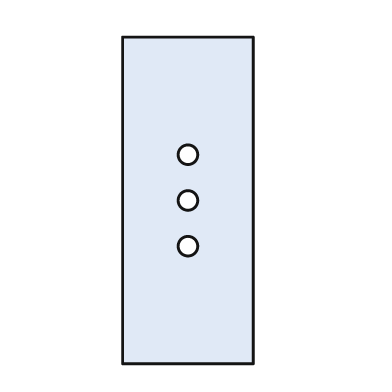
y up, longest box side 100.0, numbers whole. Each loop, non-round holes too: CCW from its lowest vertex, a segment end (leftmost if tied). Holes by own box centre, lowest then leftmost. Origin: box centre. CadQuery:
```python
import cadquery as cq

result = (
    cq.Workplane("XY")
    .moveTo(-20.0, -50.0)
    .lineTo(20.0, -50.0)
    .lineTo(20.0, 50.0)
    .lineTo(-20.0, 50.0)
    .close()
    .moveTo(0.0, -14.0)
    .circle(3.0)
    .moveTo(0.0, 0.0)
    .circle(3.0)
    .moveTo(0.0, 14.0)
    .circle(3.0)
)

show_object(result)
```